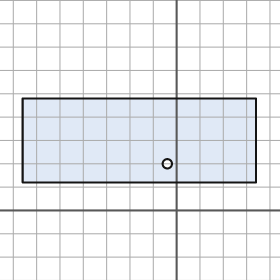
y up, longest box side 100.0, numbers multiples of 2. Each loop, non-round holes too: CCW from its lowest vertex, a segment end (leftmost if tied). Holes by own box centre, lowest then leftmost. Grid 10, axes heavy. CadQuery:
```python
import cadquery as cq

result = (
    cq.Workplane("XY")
    .moveTo(-66.0, 12.0)
    .lineTo(34.0, 12.0)
    .lineTo(34.0, 48.0)
    .lineTo(-66.0, 48.0)
    .close()
    .moveTo(-4.0, 20.0)
    .circle(2.0)
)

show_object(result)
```